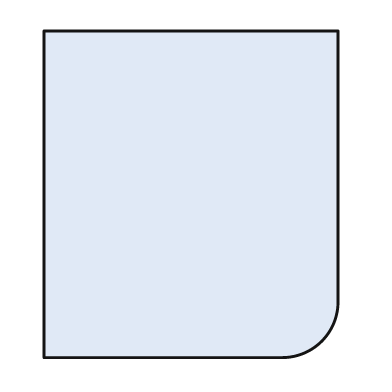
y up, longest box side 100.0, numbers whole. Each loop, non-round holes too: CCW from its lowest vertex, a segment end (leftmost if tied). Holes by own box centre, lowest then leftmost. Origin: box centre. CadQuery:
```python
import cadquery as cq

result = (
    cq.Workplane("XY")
    .moveTo(-45.0, -50.0)
    .lineTo(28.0, -50.0)
    .threePointArc((40.0, -45.0), (45.0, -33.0))
    .lineTo(45.0, 50.0)
    .lineTo(-45.0, 50.0)
    .close()
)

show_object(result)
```